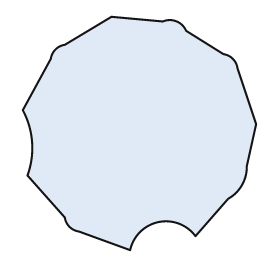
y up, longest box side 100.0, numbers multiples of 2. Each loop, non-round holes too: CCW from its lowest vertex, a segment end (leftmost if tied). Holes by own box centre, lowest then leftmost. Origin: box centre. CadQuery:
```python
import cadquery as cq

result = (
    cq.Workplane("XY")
    .moveTo(-4.0, -50.0)
    .threePointArc((8.0, -38.0), (24.0, -44.0))
    .lineTo(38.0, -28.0)
    .threePointArc((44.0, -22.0), (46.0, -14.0))
    .lineTo(50.0, 4.0)
    .lineTo(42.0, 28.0)
    .threePointArc((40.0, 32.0), (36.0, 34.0))
    .lineTo(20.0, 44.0)
    .threePointArc((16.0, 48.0), (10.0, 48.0))
    .lineTo(-12.0, 50.0)
    .lineTo(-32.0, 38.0)
    .threePointArc((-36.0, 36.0), (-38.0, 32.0))
    .lineTo(-50.0, 10.0)
    .threePointArc((-46.0, -4.0), (-48.0, -18.0))
    .lineTo(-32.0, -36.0)
    .threePointArc((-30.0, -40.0), (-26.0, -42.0))
    .close()
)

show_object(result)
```